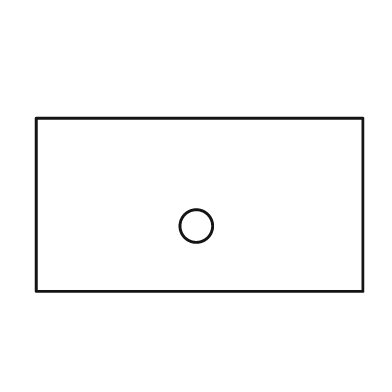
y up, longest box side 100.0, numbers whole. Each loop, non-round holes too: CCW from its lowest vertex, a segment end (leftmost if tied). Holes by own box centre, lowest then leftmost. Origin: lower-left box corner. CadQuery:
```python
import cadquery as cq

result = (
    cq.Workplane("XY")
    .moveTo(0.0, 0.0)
    .lineTo(100.0, 0.0)
    .lineTo(100.0, 53.0)
    .lineTo(0.0, 53.0)
    .close()
    .moveTo(49.0, 20.0)
    .circle(5.0)
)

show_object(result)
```